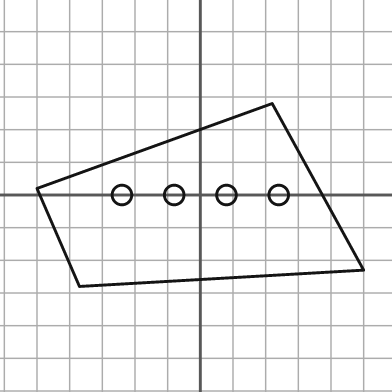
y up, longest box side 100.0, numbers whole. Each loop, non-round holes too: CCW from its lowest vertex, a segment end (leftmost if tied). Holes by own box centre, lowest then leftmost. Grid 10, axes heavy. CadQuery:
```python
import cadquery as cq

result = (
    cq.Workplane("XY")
    .moveTo(-37.0, -28.0)
    .lineTo(50.0, -23.0)
    .lineTo(22.0, 28.0)
    .lineTo(-50.0, 2.0)
    .close()
    .moveTo(-24.0, 0.0)
    .circle(3.0)
    .moveTo(-8.0, 0.0)
    .circle(3.0)
    .moveTo(8.0, 0.0)
    .circle(3.0)
    .moveTo(24.0, 0.0)
    .circle(3.0)
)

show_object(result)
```